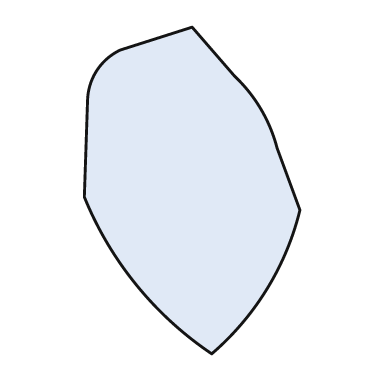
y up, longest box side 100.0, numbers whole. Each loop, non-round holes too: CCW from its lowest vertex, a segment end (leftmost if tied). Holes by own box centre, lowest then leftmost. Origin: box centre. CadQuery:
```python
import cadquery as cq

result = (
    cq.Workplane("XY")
    .moveTo(6.0, -50.0)
    .threePointArc((23.0, -30.0), (33.0, -6.0))
    .lineTo(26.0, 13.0)
    .threePointArc((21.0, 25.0), (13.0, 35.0))
    .lineTo(0.0, 50.0)
    .lineTo(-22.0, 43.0)
    .threePointArc((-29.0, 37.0), (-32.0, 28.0))
    .lineTo(-33.0, -2.0)
    .threePointArc((-17.0, -29.0), (6.0, -50.0))
    .close()
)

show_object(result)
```